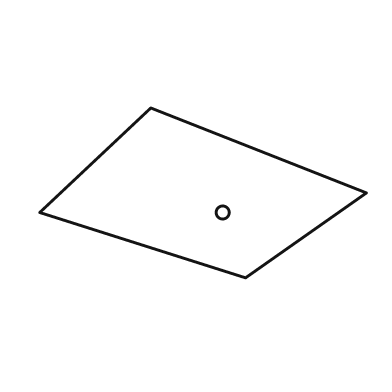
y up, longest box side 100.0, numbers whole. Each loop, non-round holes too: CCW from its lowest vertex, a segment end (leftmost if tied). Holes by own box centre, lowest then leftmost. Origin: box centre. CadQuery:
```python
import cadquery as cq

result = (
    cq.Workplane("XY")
    .moveTo(13.0, -26.0)
    .lineTo(50.0, 0.0)
    .lineTo(-16.0, 26.0)
    .lineTo(-50.0, -6.0)
    .close()
    .moveTo(6.0, -6.0)
    .circle(2.0)
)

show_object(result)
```